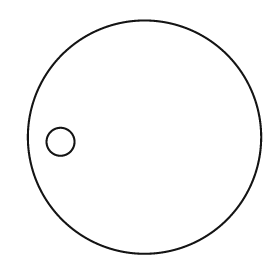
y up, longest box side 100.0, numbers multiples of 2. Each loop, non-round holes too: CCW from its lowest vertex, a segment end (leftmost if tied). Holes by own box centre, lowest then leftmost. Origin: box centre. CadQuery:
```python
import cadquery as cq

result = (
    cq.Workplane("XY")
    .moveTo(0.0, 0.0)
    .circle(50.0)
    .moveTo(-36.0, -2.0)
    .circle(6.0)
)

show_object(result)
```